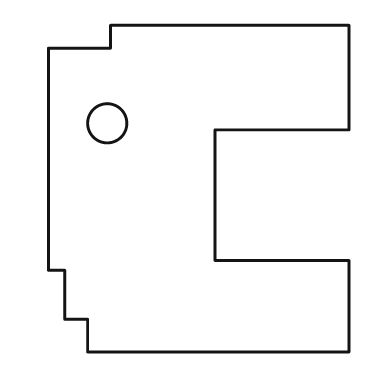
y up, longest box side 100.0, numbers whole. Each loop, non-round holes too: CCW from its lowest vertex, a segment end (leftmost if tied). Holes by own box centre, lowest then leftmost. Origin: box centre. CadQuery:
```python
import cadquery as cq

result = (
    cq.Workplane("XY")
    .moveTo(-34.0, -50.0)
    .lineTo(46.0, -50.0)
    .lineTo(46.0, -22.0)
    .lineTo(5.0, -22.0)
    .lineTo(5.0, 18.0)
    .lineTo(46.0, 18.0)
    .lineTo(46.0, 50.0)
    .lineTo(-27.0, 50.0)
    .lineTo(-27.0, 43.0)
    .lineTo(-46.0, 43.0)
    .lineTo(-46.0, -25.0)
    .lineTo(-41.0, -25.0)
    .lineTo(-41.0, -40.0)
    .lineTo(-34.0, -40.0)
    .close()
    .moveTo(-28.0, 20.0)
    .circle(6.0)
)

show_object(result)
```